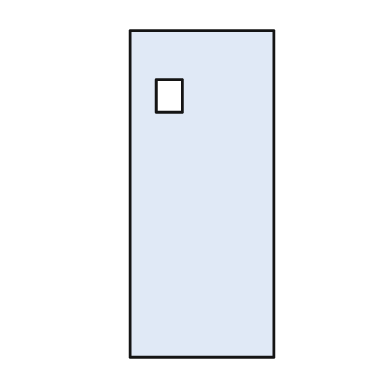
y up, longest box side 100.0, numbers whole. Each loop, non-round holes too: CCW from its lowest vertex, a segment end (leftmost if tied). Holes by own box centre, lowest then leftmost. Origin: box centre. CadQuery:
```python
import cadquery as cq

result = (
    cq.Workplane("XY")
    .moveTo(-22.0, -50.0)
    .lineTo(22.0, -50.0)
    .lineTo(22.0, 50.0)
    .lineTo(-22.0, 50.0)
    .close()
    .moveTo(-14.0, 25.0)
    .lineTo(-6.0, 25.0)
    .lineTo(-6.0, 35.0)
    .lineTo(-14.0, 35.0)
    .close()
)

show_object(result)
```